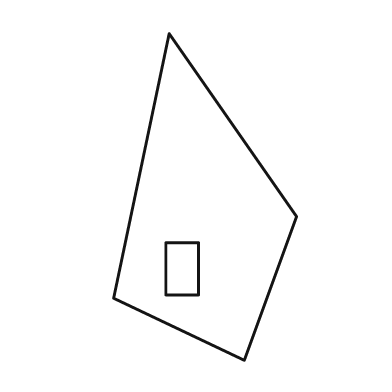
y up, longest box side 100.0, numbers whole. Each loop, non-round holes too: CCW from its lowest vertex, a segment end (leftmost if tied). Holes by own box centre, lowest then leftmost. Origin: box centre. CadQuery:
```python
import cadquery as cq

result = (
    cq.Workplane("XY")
    .moveTo(12.0, -50.0)
    .lineTo(28.0, -6.0)
    .lineTo(-11.0, 50.0)
    .lineTo(-28.0, -31.0)
    .close()
    .moveTo(-12.0, -30.0)
    .lineTo(-2.0, -30.0)
    .lineTo(-2.0, -14.0)
    .lineTo(-12.0, -14.0)
    .close()
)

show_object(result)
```